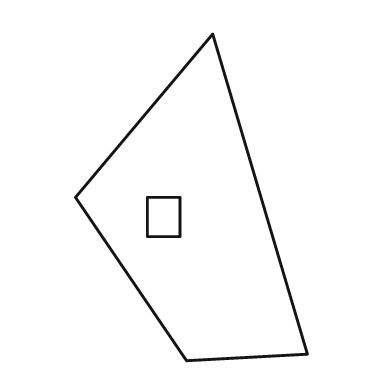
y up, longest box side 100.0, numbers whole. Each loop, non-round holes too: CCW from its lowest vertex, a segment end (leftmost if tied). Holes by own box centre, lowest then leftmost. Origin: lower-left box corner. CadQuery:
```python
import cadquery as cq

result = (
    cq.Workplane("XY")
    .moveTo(34.0, 0.0)
    .lineTo(71.0, 2.0)
    .lineTo(42.0, 100.0)
    .lineTo(0.0, 50.0)
    .close()
    .moveTo(22.0, 38.0)
    .lineTo(32.0, 38.0)
    .lineTo(32.0, 50.0)
    .lineTo(22.0, 50.0)
    .close()
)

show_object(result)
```